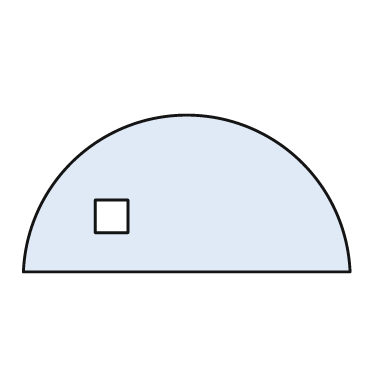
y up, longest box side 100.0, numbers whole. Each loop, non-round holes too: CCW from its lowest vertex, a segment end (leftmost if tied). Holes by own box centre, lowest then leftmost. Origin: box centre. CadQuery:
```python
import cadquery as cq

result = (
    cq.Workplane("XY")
    .moveTo(-50.0, -24.0)
    .lineTo(50.0, -24.0)
    .threePointArc((0.0, 24.0), (-50.0, -24.0))
    .close()
    .moveTo(-28.0, -12.0)
    .lineTo(-18.0, -12.0)
    .lineTo(-18.0, -2.0)
    .lineTo(-28.0, -2.0)
    .close()
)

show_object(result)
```